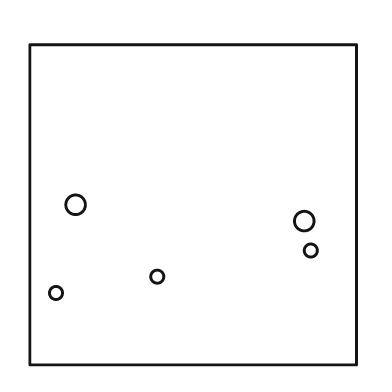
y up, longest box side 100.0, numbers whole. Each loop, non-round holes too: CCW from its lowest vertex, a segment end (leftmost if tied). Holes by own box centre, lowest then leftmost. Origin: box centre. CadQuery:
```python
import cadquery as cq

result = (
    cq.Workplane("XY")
    .moveTo(-50.0, -49.0)
    .lineTo(50.0, -49.0)
    .lineTo(50.0, 49.0)
    .lineTo(-50.0, 49.0)
    .close()
    .moveTo(-42.0, -27.0)
    .circle(2.0)
    .moveTo(-11.0, -22.0)
    .circle(2.0)
    .moveTo(36.0, -14.0)
    .circle(2.0)
    .moveTo(34.0, -5.0)
    .circle(3.0)
    .moveTo(-36.0, 0.0)
    .circle(3.0)
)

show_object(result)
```